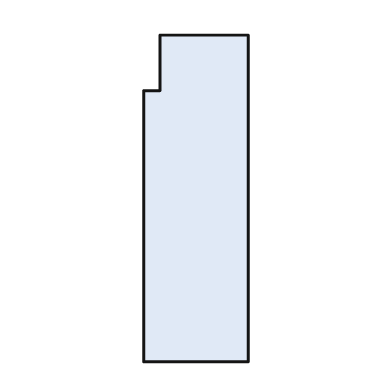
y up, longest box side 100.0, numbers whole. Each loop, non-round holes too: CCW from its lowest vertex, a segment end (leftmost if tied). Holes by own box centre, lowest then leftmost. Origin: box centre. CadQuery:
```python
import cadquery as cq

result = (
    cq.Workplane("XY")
    .moveTo(-16.0, -50.0)
    .lineTo(16.0, -50.0)
    .lineTo(16.0, 50.0)
    .lineTo(-11.0, 50.0)
    .lineTo(-11.0, 33.0)
    .lineTo(-16.0, 33.0)
    .close()
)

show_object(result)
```